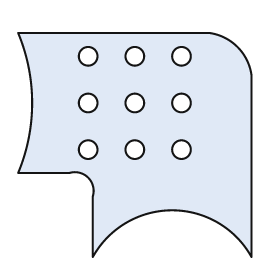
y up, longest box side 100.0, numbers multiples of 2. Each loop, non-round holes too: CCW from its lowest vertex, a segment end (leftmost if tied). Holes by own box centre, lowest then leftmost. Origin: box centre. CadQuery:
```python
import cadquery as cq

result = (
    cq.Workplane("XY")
    .moveTo(-18.0, -48.0)
    .threePointArc((16.0, -28.0), (50.0, -48.0))
    .lineTo(50.0, 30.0)
    .threePointArc((44.0, 42.0), (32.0, 48.0))
    .lineTo(-50.0, 48.0)
    .threePointArc((-44.0, 18.0), (-50.0, -12.0))
    .lineTo(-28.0, -12.0)
    .threePointArc((-20.0, -14.0), (-18.0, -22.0))
    .close()
    .moveTo(-20.0, -2.0)
    .circle(4.0)
    .moveTo(0.0, -2.0)
    .circle(4.0)
    .moveTo(20.0, -2.0)
    .circle(4.0)
    .moveTo(-20.0, 18.0)
    .circle(4.0)
    .moveTo(0.0, 18.0)
    .circle(4.0)
    .moveTo(20.0, 18.0)
    .circle(4.0)
    .moveTo(-20.0, 38.0)
    .circle(4.0)
    .moveTo(0.0, 38.0)
    .circle(4.0)
    .moveTo(20.0, 38.0)
    .circle(4.0)
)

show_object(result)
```